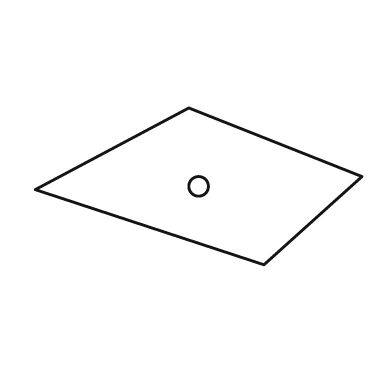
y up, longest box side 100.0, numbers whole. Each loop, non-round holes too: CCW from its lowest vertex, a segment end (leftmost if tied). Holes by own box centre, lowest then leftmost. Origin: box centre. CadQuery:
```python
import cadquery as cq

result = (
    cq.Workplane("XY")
    .moveTo(20.0, -24.0)
    .lineTo(50.0, 3.0)
    .lineTo(-3.0, 24.0)
    .lineTo(-50.0, -1.0)
    .close()
    .moveTo(0.0, 0.0)
    .circle(3.0)
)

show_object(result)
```